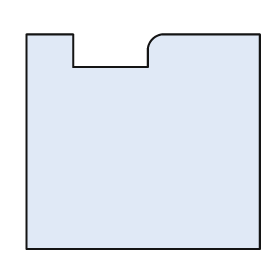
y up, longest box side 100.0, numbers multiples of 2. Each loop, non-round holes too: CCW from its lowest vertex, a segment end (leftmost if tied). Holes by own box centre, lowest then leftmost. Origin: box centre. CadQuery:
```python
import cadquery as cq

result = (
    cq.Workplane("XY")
    .moveTo(-50.0, -46.0)
    .lineTo(50.0, -46.0)
    .lineTo(50.0, 46.0)
    .lineTo(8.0, 46.0)
    .threePointArc((4.0, 44.0), (2.0, 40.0))
    .lineTo(2.0, 32.0)
    .lineTo(-30.0, 32.0)
    .lineTo(-30.0, 46.0)
    .lineTo(-50.0, 46.0)
    .close()
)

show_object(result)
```